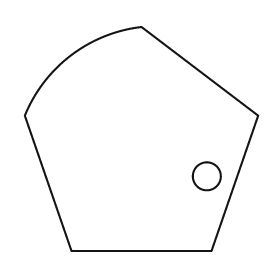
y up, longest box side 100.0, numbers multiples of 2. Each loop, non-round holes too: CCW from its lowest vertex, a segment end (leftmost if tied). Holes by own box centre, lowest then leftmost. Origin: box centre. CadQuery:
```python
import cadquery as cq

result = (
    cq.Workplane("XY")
    .moveTo(-30.0, -48.0)
    .lineTo(30.0, -48.0)
    .lineTo(50.0, 10.0)
    .lineTo(0.0, 48.0)
    .threePointArc((-30.0, 36.0), (-50.0, 10.0))
    .close()
    .moveTo(28.0, -16.0)
    .circle(6.0)
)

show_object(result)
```